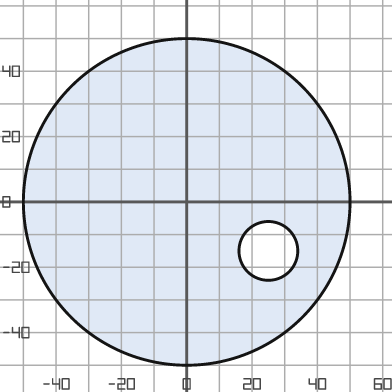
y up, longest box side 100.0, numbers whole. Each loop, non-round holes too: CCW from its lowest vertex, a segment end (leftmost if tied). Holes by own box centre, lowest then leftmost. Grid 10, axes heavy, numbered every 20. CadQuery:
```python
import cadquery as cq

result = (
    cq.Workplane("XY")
    .moveTo(0.0, 0.0)
    .circle(50.0)
    .moveTo(25.0, -15.0)
    .circle(9.0)
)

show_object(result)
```